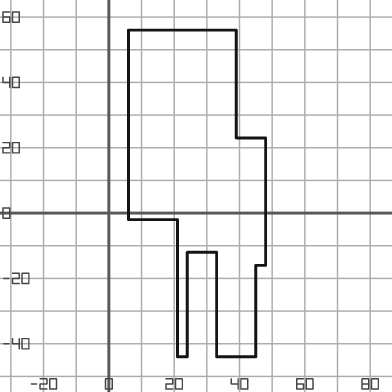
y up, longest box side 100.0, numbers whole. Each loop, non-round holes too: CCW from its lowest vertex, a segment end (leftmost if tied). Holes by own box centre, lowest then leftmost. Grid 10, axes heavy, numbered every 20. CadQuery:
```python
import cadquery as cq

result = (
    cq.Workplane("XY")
    .moveTo(21.0, -44.0)
    .lineTo(24.0, -44.0)
    .lineTo(24.0, -12.0)
    .lineTo(33.0, -12.0)
    .lineTo(33.0, -44.0)
    .lineTo(45.0, -44.0)
    .lineTo(45.0, -16.0)
    .lineTo(48.0, -16.0)
    .lineTo(48.0, 23.0)
    .lineTo(39.0, 23.0)
    .lineTo(39.0, 56.0)
    .lineTo(6.0, 56.0)
    .lineTo(6.0, -2.0)
    .lineTo(21.0, -2.0)
    .close()
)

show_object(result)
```